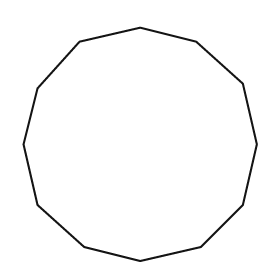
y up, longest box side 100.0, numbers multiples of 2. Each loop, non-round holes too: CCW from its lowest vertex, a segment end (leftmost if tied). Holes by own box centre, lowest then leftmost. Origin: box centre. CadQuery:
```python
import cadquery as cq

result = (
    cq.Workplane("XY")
    .moveTo(0.0, -50.0)
    .lineTo(26.0, -44.0)
    .lineTo(44.0, -26.0)
    .lineTo(50.0, 0.0)
    .lineTo(44.0, 26.0)
    .lineTo(24.0, 44.0)
    .lineTo(0.0, 50.0)
    .lineTo(-26.0, 44.0)
    .lineTo(-44.0, 24.0)
    .lineTo(-50.0, 0.0)
    .lineTo(-44.0, -26.0)
    .lineTo(-24.0, -44.0)
    .close()
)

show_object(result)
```